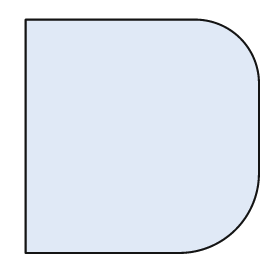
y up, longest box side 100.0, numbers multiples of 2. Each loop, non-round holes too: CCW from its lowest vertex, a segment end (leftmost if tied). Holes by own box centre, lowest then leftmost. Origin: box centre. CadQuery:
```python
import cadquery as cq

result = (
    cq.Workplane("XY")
    .moveTo(-50.0, -50.0)
    .lineTo(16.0, -50.0)
    .threePointArc((40.0, -40.0), (50.0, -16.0))
    .lineTo(50.0, 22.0)
    .threePointArc((42.0, 42.0), (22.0, 50.0))
    .lineTo(-50.0, 50.0)
    .close()
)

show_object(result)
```